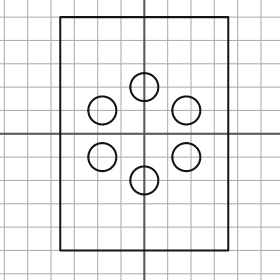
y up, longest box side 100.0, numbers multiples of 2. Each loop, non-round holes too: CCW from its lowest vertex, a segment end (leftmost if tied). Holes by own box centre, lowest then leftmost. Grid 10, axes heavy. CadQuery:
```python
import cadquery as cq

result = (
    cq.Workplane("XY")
    .moveTo(-36.0, -50.0)
    .lineTo(36.0, -50.0)
    .lineTo(36.0, 50.0)
    .lineTo(-36.0, 50.0)
    .close()
    .moveTo(0.0, -20.0)
    .circle(6.0)
    .moveTo(-18.0, -10.0)
    .circle(6.0)
    .moveTo(18.0, -10.0)
    .circle(6.0)
    .moveTo(-18.0, 10.0)
    .circle(6.0)
    .moveTo(18.0, 10.0)
    .circle(6.0)
    .moveTo(0.0, 20.0)
    .circle(6.0)
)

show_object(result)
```